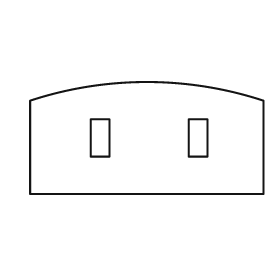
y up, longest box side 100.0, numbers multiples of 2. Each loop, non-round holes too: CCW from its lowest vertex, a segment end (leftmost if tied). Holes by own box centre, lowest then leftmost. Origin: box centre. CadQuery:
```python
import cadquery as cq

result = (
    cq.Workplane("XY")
    .moveTo(-50.0, -24.0)
    .lineTo(50.0, -24.0)
    .lineTo(50.0, 16.0)
    .threePointArc((0.0, 24.0), (-50.0, 16.0))
    .close()
    .moveTo(-24.0, -8.0)
    .lineTo(-16.0, -8.0)
    .lineTo(-16.0, 8.0)
    .lineTo(-24.0, 8.0)
    .close()
    .moveTo(18.0, -8.0)
    .lineTo(26.0, -8.0)
    .lineTo(26.0, 8.0)
    .lineTo(18.0, 8.0)
    .close()
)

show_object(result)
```